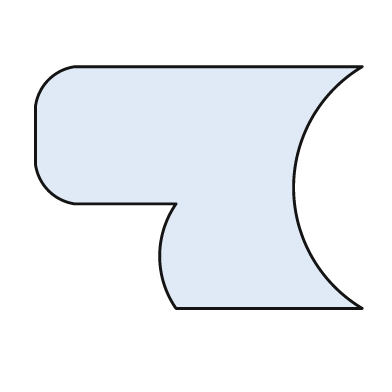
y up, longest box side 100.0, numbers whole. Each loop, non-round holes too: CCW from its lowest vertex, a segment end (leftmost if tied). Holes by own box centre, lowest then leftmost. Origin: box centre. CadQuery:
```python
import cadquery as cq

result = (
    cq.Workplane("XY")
    .moveTo(-7.0, -37.0)
    .lineTo(50.0, -37.0)
    .threePointArc((29.0, 0.0), (50.0, 37.0))
    .lineTo(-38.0, 37.0)
    .threePointArc((-46.0, 33.0), (-50.0, 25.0))
    .lineTo(-50.0, 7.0)
    .threePointArc((-46.0, -1.0), (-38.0, -5.0))
    .lineTo(-7.0, -5.0)
    .threePointArc((-12.0, -21.0), (-7.0, -37.0))
    .close()
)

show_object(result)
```